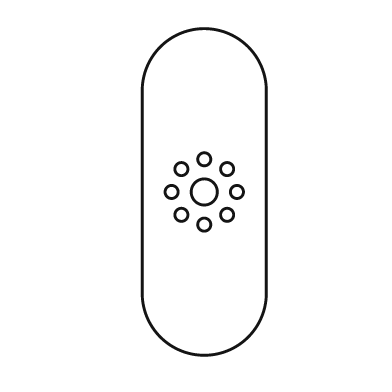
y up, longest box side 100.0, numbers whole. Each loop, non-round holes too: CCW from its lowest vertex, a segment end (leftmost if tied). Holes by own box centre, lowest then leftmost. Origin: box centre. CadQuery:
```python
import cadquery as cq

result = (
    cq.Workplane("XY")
    .moveTo(-19.0, -31.0)
    .threePointArc((0.0, -50.0), (19.0, -31.0))
    .lineTo(19.0, 31.0)
    .threePointArc((0.0, 50.0), (-19.0, 31.0))
    .close()
    .moveTo(0.0, -10.0)
    .circle(2.0)
    .moveTo(-7.0, -7.0)
    .circle(2.0)
    .moveTo(7.0, -7.0)
    .circle(2.0)
    .moveTo(-10.0, 0.0)
    .circle(2.0)
    .moveTo(0.0, 0.0)
    .circle(4.0)
    .moveTo(10.0, 0.0)
    .circle(2.0)
    .moveTo(-7.0, 7.0)
    .circle(2.0)
    .moveTo(7.0, 7.0)
    .circle(2.0)
    .moveTo(0.0, 10.0)
    .circle(2.0)
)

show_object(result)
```